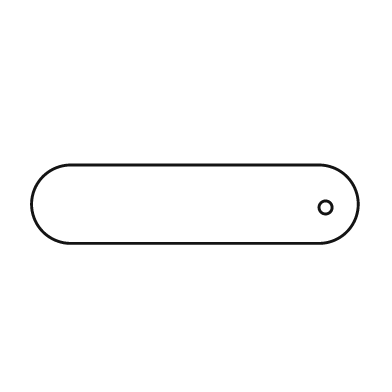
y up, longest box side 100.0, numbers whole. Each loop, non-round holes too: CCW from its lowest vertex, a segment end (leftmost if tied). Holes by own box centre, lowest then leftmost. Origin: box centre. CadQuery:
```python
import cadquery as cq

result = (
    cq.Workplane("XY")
    .moveTo(-38.0, -12.0)
    .lineTo(38.0, -12.0)
    .threePointArc((50.0, 0.0), (38.0, 12.0))
    .lineTo(-38.0, 12.0)
    .threePointArc((-50.0, 0.0), (-38.0, -12.0))
    .close()
    .moveTo(40.0, -1.0)
    .circle(2.0)
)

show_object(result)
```